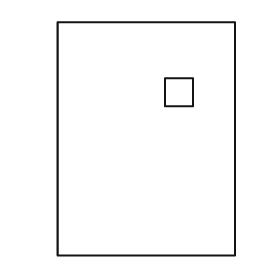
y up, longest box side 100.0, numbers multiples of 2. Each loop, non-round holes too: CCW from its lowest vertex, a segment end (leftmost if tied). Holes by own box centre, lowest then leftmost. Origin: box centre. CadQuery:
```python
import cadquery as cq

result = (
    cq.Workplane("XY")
    .moveTo(-38.0, -50.0)
    .lineTo(38.0, -50.0)
    .lineTo(38.0, 50.0)
    .lineTo(-38.0, 50.0)
    .close()
    .moveTo(8.0, 14.0)
    .lineTo(20.0, 14.0)
    .lineTo(20.0, 26.0)
    .lineTo(8.0, 26.0)
    .close()
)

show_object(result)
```